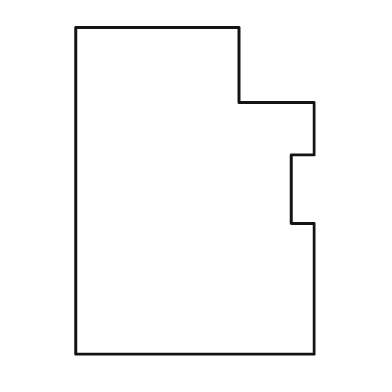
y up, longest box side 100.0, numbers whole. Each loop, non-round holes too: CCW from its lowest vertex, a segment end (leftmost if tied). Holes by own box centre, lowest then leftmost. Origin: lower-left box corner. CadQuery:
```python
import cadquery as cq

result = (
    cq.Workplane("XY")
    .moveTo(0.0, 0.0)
    .lineTo(73.0, 0.0)
    .lineTo(73.0, 40.0)
    .lineTo(66.0, 40.0)
    .lineTo(66.0, 61.0)
    .lineTo(73.0, 61.0)
    .lineTo(73.0, 77.0)
    .lineTo(50.0, 77.0)
    .lineTo(50.0, 100.0)
    .lineTo(0.0, 100.0)
    .close()
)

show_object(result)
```